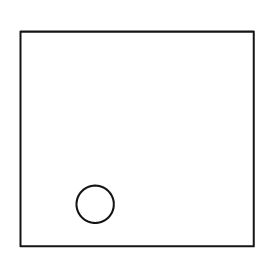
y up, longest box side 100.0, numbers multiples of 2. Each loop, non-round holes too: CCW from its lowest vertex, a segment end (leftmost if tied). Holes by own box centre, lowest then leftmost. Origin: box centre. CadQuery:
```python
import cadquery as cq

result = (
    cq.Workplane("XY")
    .moveTo(-50.0, -46.0)
    .lineTo(50.0, -46.0)
    .lineTo(50.0, 46.0)
    .lineTo(-50.0, 46.0)
    .close()
    .moveTo(-18.0, -28.0)
    .circle(8.0)
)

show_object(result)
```